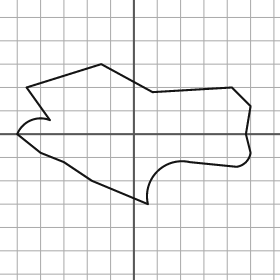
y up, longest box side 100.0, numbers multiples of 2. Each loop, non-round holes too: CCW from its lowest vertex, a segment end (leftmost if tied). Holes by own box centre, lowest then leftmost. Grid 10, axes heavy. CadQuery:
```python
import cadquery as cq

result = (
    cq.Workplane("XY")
    .moveTo(6.0, -30.0)
    .threePointArc((10.0, -16.0), (24.0, -12.0))
    .lineTo(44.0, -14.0)
    .threePointArc((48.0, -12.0), (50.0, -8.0))
    .lineTo(48.0, 0.0)
    .lineTo(50.0, 12.0)
    .lineTo(42.0, 20.0)
    .lineTo(8.0, 18.0)
    .lineTo(-14.0, 30.0)
    .lineTo(-46.0, 20.0)
    .lineTo(-36.0, 6.0)
    .threePointArc((-44.0, 6.0), (-50.0, 0.0))
    .lineTo(-40.0, -8.0)
    .lineTo(-30.0, -12.0)
    .lineTo(-18.0, -20.0)
    .close()
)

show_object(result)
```